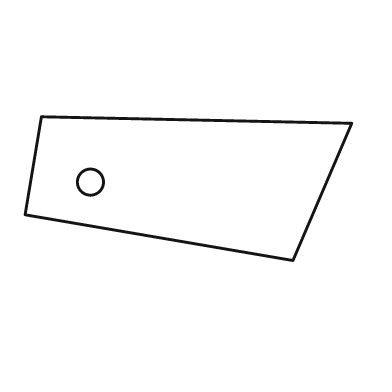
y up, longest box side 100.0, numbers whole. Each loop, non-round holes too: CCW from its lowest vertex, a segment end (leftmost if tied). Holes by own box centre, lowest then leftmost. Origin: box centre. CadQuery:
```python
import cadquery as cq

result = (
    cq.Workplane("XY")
    .moveTo(32.0, -22.0)
    .lineTo(50.0, 20.0)
    .lineTo(-45.0, 22.0)
    .lineTo(-50.0, -8.0)
    .close()
    .moveTo(-30.0, 2.0)
    .circle(4.0)
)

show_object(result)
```